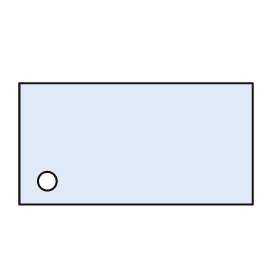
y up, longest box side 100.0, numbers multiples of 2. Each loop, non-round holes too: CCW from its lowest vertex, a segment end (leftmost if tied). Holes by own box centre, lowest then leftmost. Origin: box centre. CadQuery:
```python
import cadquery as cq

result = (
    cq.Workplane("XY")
    .moveTo(-50.0, -26.0)
    .lineTo(50.0, -26.0)
    .lineTo(50.0, 26.0)
    .lineTo(-50.0, 26.0)
    .close()
    .moveTo(-38.0, -16.0)
    .circle(4.0)
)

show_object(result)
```